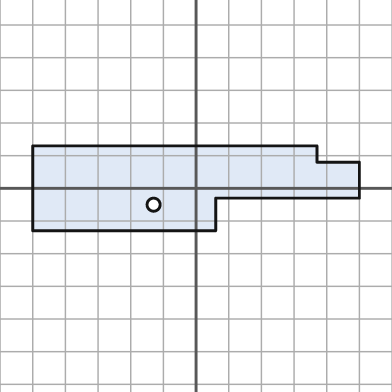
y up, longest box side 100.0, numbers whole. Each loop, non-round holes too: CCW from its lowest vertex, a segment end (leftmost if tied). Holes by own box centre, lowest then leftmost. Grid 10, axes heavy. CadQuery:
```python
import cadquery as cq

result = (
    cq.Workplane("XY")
    .moveTo(-50.0, -13.0)
    .lineTo(6.0, -13.0)
    .lineTo(6.0, -3.0)
    .lineTo(50.0, -3.0)
    .lineTo(50.0, 8.0)
    .lineTo(37.0, 8.0)
    .lineTo(37.0, 13.0)
    .lineTo(-50.0, 13.0)
    .close()
    .moveTo(-13.0, -5.0)
    .circle(2.0)
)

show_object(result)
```